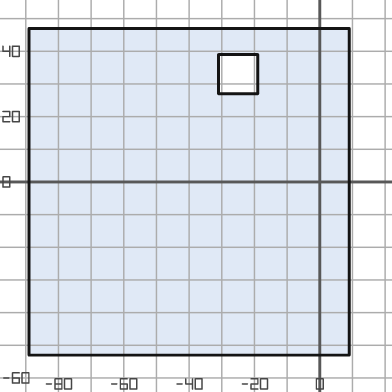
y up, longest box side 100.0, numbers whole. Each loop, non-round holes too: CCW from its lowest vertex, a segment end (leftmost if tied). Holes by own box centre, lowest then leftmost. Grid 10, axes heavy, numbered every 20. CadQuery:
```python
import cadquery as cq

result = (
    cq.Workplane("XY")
    .moveTo(-89.0, -53.0)
    .lineTo(9.0, -53.0)
    .lineTo(9.0, 47.0)
    .lineTo(-89.0, 47.0)
    .close()
    .moveTo(-31.0, 27.0)
    .lineTo(-19.0, 27.0)
    .lineTo(-19.0, 39.0)
    .lineTo(-31.0, 39.0)
    .close()
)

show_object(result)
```